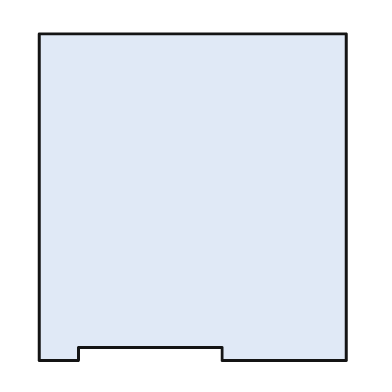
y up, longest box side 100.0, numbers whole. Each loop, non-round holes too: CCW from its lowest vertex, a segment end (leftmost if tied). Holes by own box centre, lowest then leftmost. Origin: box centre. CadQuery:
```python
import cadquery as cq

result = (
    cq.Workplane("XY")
    .moveTo(-47.0, -50.0)
    .lineTo(-35.0, -50.0)
    .lineTo(-35.0, -46.0)
    .lineTo(9.0, -46.0)
    .lineTo(9.0, -50.0)
    .lineTo(47.0, -50.0)
    .lineTo(47.0, 50.0)
    .lineTo(-47.0, 50.0)
    .close()
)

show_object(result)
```